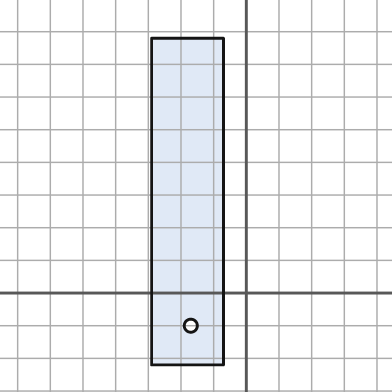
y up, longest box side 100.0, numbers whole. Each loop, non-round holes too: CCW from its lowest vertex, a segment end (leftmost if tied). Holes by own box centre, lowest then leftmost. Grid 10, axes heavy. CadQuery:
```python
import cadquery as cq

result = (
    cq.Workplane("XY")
    .moveTo(-29.0, -22.0)
    .lineTo(-7.0, -22.0)
    .lineTo(-7.0, 78.0)
    .lineTo(-29.0, 78.0)
    .close()
    .moveTo(-17.0, -10.0)
    .circle(2.0)
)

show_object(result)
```